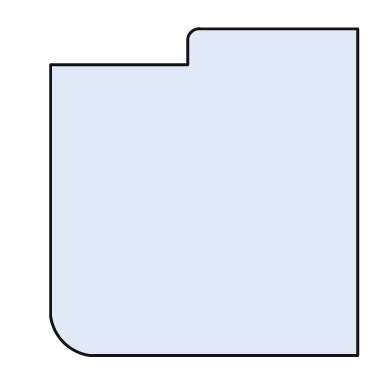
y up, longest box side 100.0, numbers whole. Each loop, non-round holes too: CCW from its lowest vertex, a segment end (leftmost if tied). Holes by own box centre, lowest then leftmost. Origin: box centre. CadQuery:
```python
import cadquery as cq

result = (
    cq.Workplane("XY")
    .moveTo(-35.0, -50.0)
    .lineTo(47.0, -50.0)
    .lineTo(47.0, 50.0)
    .lineTo(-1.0, 50.0)
    .threePointArc((-4.0, 49.0), (-5.0, 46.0))
    .lineTo(-5.0, 39.0)
    .lineTo(-47.0, 39.0)
    .lineTo(-47.0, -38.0)
    .threePointArc((-43.0, -46.0), (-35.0, -50.0))
    .close()
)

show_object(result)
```